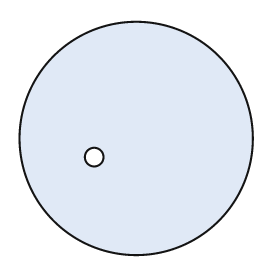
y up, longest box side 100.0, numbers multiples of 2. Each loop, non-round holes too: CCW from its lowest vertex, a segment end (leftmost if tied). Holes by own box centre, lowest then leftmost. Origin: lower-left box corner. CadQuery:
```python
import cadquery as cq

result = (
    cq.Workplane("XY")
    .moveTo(50.0, 50.0)
    .circle(50.0)
    .moveTo(32.0, 42.0)
    .circle(4.0)
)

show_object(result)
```